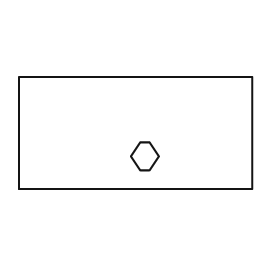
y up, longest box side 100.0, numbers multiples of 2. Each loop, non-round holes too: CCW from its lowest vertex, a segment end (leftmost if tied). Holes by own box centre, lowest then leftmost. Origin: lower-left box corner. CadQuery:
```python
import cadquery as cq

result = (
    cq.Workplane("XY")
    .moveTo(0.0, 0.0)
    .lineTo(100.0, 0.0)
    .lineTo(100.0, 48.0)
    .lineTo(0.0, 48.0)
    .close()
    .moveTo(52.0, 8.0)
    .lineTo(56.0, 8.0)
    .lineTo(60.0, 14.0)
    .lineTo(56.0, 20.0)
    .lineTo(52.0, 20.0)
    .lineTo(48.0, 14.0)
    .close()
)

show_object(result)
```